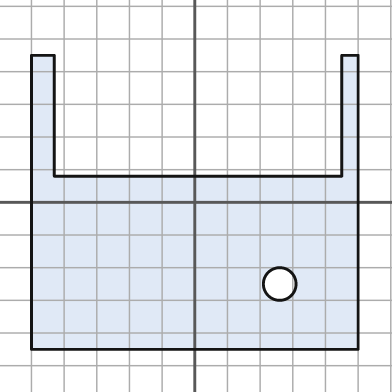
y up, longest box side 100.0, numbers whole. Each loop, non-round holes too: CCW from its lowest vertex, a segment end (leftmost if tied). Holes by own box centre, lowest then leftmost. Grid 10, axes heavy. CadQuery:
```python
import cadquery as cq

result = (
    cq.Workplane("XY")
    .moveTo(-50.0, -45.0)
    .lineTo(50.0, -45.0)
    .lineTo(50.0, 45.0)
    .lineTo(45.0, 45.0)
    .lineTo(45.0, 8.0)
    .lineTo(-43.0, 8.0)
    .lineTo(-43.0, 45.0)
    .lineTo(-50.0, 45.0)
    .close()
    .moveTo(26.0, -25.0)
    .circle(5.0)
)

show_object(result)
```